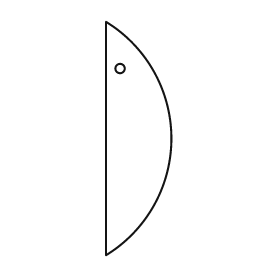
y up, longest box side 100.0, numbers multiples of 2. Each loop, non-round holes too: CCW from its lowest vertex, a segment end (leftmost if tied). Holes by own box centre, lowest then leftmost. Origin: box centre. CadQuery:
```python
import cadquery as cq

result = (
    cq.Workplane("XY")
    .moveTo(-14.0, -50.0)
    .threePointArc((14.0, 0.0), (-14.0, 50.0))
    .close()
    .moveTo(-8.0, 30.0)
    .circle(2.0)
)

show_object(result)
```